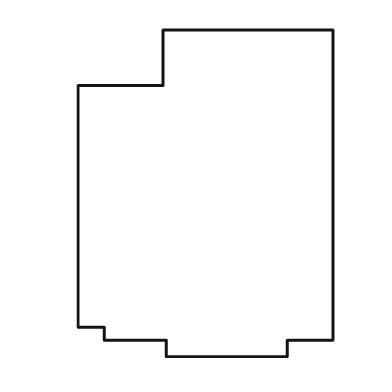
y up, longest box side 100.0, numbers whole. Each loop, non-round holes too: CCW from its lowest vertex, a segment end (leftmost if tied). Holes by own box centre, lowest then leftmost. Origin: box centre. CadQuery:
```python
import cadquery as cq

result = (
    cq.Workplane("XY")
    .moveTo(-12.0, -50.0)
    .lineTo(25.0, -50.0)
    .lineTo(25.0, -45.0)
    .lineTo(39.0, -45.0)
    .lineTo(39.0, 50.0)
    .lineTo(-13.0, 50.0)
    .lineTo(-13.0, 33.0)
    .lineTo(-39.0, 33.0)
    .lineTo(-39.0, -41.0)
    .lineTo(-31.0, -41.0)
    .lineTo(-31.0, -45.0)
    .lineTo(-12.0, -45.0)
    .close()
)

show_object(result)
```